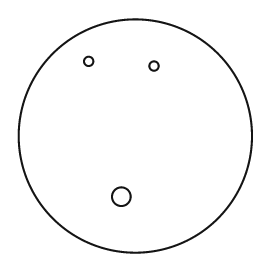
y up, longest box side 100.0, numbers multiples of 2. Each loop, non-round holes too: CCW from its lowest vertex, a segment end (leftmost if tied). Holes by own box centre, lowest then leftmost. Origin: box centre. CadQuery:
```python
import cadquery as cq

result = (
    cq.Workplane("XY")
    .moveTo(0.0, 0.0)
    .circle(50.0)
    .moveTo(-6.0, -26.0)
    .circle(4.0)
    .moveTo(8.0, 30.0)
    .circle(2.0)
    .moveTo(-20.0, 32.0)
    .circle(2.0)
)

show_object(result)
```